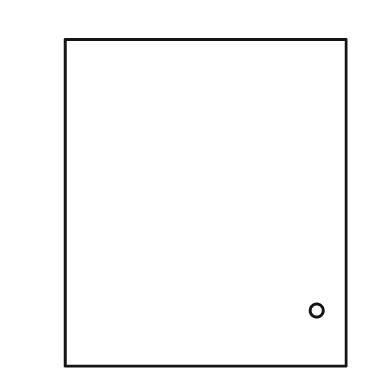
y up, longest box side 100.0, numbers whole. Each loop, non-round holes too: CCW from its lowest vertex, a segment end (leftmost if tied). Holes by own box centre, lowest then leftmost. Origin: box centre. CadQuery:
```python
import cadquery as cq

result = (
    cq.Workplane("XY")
    .moveTo(-43.0, -50.0)
    .lineTo(43.0, -50.0)
    .lineTo(43.0, 50.0)
    .lineTo(-43.0, 50.0)
    .close()
    .moveTo(34.0, -33.0)
    .circle(2.0)
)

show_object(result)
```